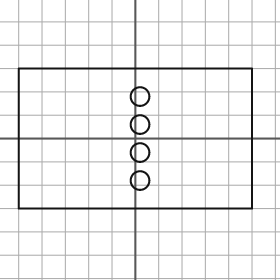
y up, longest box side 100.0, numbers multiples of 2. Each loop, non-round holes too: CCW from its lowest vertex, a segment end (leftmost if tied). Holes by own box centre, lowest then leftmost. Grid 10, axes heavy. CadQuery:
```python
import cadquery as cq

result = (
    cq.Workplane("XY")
    .moveTo(-50.0, -30.0)
    .lineTo(50.0, -30.0)
    .lineTo(50.0, 30.0)
    .lineTo(-50.0, 30.0)
    .close()
    .moveTo(2.0, -18.0)
    .circle(4.0)
    .moveTo(2.0, -6.0)
    .circle(4.0)
    .moveTo(2.0, 6.0)
    .circle(4.0)
    .moveTo(2.0, 18.0)
    .circle(4.0)
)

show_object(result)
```